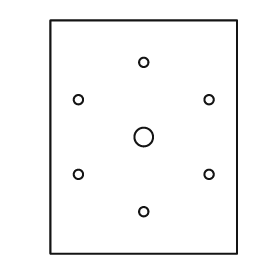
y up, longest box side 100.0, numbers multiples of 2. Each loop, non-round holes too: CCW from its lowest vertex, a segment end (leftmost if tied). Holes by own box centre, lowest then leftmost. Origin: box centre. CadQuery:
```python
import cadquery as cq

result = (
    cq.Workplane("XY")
    .moveTo(-40.0, -50.0)
    .lineTo(40.0, -50.0)
    .lineTo(40.0, 50.0)
    .lineTo(-40.0, 50.0)
    .close()
    .moveTo(0.0, -32.0)
    .circle(2.0)
    .moveTo(-28.0, -16.0)
    .circle(2.0)
    .moveTo(28.0, -16.0)
    .circle(2.0)
    .moveTo(0.0, 0.0)
    .circle(4.0)
    .moveTo(-28.0, 16.0)
    .circle(2.0)
    .moveTo(28.0, 16.0)
    .circle(2.0)
    .moveTo(0.0, 32.0)
    .circle(2.0)
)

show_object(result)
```